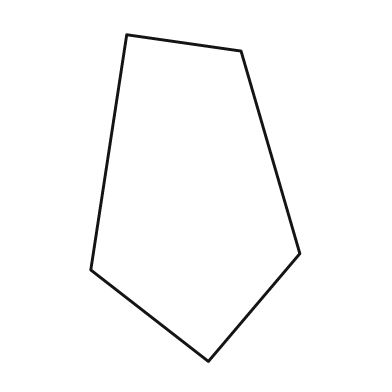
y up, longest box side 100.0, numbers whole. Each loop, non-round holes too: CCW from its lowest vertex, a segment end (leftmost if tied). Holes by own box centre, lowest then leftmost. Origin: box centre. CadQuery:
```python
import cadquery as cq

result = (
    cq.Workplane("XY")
    .moveTo(4.0, -50.0)
    .lineTo(32.0, -17.0)
    .lineTo(14.0, 45.0)
    .lineTo(-21.0, 50.0)
    .lineTo(-32.0, -22.0)
    .close()
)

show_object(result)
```